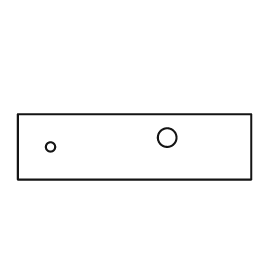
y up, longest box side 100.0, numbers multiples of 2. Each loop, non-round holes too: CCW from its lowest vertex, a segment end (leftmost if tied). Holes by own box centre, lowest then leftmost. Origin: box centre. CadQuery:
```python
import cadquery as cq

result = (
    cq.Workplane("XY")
    .moveTo(-50.0, -14.0)
    .lineTo(50.0, -14.0)
    .lineTo(50.0, 14.0)
    .lineTo(-50.0, 14.0)
    .close()
    .moveTo(-36.0, 0.0)
    .circle(2.0)
    .moveTo(14.0, 4.0)
    .circle(4.0)
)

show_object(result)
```